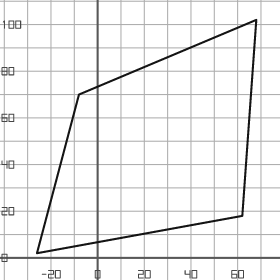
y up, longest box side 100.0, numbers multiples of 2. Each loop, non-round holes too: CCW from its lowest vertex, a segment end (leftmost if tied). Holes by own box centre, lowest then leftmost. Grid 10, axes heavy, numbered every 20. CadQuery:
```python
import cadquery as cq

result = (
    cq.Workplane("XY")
    .moveTo(-26.0, 2.0)
    .lineTo(62.0, 18.0)
    .lineTo(68.0, 102.0)
    .lineTo(-8.0, 70.0)
    .close()
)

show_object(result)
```